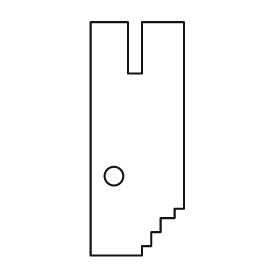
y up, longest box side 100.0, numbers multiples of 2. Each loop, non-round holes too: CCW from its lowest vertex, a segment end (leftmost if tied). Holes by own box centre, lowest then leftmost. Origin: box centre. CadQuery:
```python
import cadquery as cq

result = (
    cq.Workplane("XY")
    .moveTo(-20.0, -50.0)
    .lineTo(2.0, -50.0)
    .lineTo(2.0, -46.0)
    .lineTo(6.0, -46.0)
    .lineTo(6.0, -40.0)
    .lineTo(10.0, -40.0)
    .lineTo(10.0, -34.0)
    .lineTo(16.0, -34.0)
    .lineTo(16.0, -30.0)
    .lineTo(20.0, -30.0)
    .lineTo(20.0, 50.0)
    .lineTo(2.0, 50.0)
    .lineTo(2.0, 28.0)
    .lineTo(-4.0, 28.0)
    .lineTo(-4.0, 50.0)
    .lineTo(-20.0, 50.0)
    .close()
    .moveTo(-10.0, -16.0)
    .circle(4.0)
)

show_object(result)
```